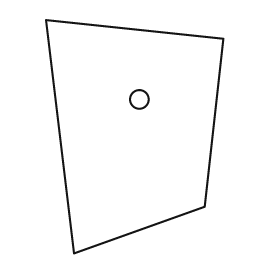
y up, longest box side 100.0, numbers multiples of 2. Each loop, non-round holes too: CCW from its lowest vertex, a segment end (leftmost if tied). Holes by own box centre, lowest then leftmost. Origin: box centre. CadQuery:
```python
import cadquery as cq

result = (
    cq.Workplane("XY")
    .moveTo(-26.0, -50.0)
    .lineTo(30.0, -30.0)
    .lineTo(38.0, 42.0)
    .lineTo(-38.0, 50.0)
    .close()
    .moveTo(2.0, 16.0)
    .circle(4.0)
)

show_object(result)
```